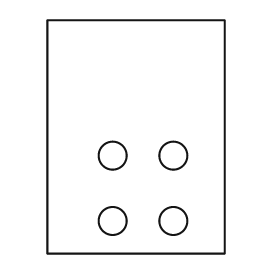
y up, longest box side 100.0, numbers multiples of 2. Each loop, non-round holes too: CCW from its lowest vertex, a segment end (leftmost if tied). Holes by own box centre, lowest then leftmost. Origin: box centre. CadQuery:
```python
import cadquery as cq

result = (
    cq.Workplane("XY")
    .moveTo(-38.0, -50.0)
    .lineTo(38.0, -50.0)
    .lineTo(38.0, 50.0)
    .lineTo(-38.0, 50.0)
    .close()
    .moveTo(-10.0, -36.0)
    .circle(6.0)
    .moveTo(16.0, -36.0)
    .circle(6.0)
    .moveTo(-10.0, -8.0)
    .circle(6.0)
    .moveTo(16.0, -8.0)
    .circle(6.0)
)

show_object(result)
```